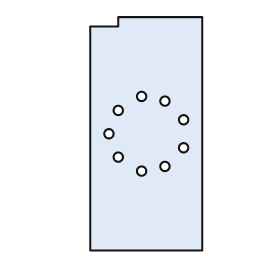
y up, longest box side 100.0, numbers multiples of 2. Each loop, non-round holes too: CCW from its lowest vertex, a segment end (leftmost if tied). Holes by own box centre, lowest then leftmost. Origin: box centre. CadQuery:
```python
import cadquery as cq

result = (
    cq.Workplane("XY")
    .moveTo(-24.0, -50.0)
    .lineTo(24.0, -50.0)
    .lineTo(24.0, 50.0)
    .lineTo(-12.0, 50.0)
    .lineTo(-12.0, 46.0)
    .lineTo(-24.0, 46.0)
    .close()
    .moveTo(-2.0, -16.0)
    .circle(2.0)
    .moveTo(8.0, -14.0)
    .circle(2.0)
    .moveTo(-12.0, -10.0)
    .circle(2.0)
    .moveTo(16.0, -6.0)
    .circle(2.0)
    .moveTo(-16.0, 0.0)
    .circle(2.0)
    .moveTo(16.0, 6.0)
    .circle(2.0)
    .moveTo(-12.0, 10.0)
    .circle(2.0)
    .moveTo(8.0, 14.0)
    .circle(2.0)
    .moveTo(-2.0, 16.0)
    .circle(2.0)
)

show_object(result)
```